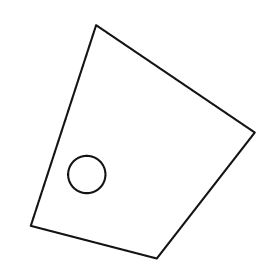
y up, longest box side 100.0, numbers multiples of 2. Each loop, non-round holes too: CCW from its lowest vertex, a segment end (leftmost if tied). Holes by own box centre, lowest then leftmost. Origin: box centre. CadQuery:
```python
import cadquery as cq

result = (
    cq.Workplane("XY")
    .moveTo(6.0, -50.0)
    .lineTo(48.0, 4.0)
    .lineTo(-20.0, 50.0)
    .lineTo(-48.0, -36.0)
    .close()
    .moveTo(-24.0, -14.0)
    .circle(8.0)
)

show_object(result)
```